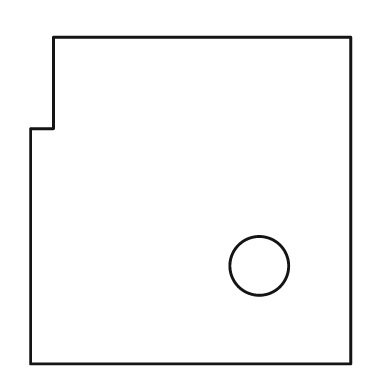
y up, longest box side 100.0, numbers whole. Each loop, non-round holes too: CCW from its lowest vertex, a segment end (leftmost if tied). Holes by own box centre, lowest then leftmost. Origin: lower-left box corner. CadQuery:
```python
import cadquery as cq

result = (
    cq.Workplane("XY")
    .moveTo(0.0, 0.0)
    .lineTo(98.0, 0.0)
    .lineTo(98.0, 100.0)
    .lineTo(7.0, 100.0)
    .lineTo(7.0, 72.0)
    .lineTo(0.0, 72.0)
    .close()
    .moveTo(70.0, 30.0)
    .circle(9.0)
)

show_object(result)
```